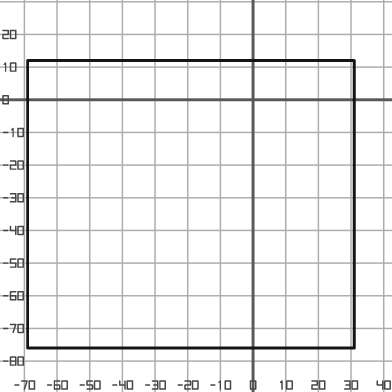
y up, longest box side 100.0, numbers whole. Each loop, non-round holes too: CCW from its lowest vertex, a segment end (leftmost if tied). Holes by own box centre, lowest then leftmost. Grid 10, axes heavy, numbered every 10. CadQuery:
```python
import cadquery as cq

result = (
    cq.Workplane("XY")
    .moveTo(-69.0, -76.0)
    .lineTo(31.0, -76.0)
    .lineTo(31.0, 12.0)
    .lineTo(-69.0, 12.0)
    .close()
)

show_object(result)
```